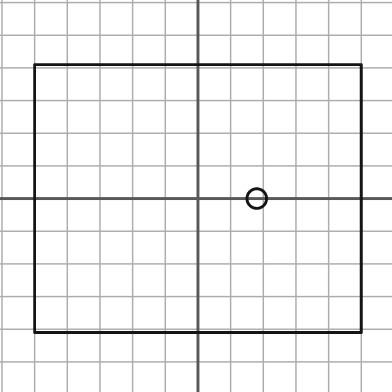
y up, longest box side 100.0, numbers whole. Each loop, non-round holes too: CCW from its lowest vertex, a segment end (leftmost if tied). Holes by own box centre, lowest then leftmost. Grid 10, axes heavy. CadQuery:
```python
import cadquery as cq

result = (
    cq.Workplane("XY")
    .moveTo(-50.0, -41.0)
    .lineTo(50.0, -41.0)
    .lineTo(50.0, 41.0)
    .lineTo(-50.0, 41.0)
    .close()
    .moveTo(18.0, 0.0)
    .circle(3.0)
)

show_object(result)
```